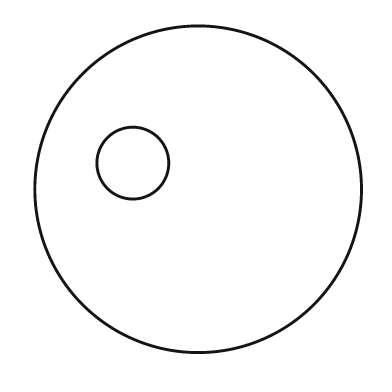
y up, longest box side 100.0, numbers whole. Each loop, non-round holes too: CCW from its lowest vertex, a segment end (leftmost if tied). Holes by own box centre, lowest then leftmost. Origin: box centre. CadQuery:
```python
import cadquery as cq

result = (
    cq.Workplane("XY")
    .moveTo(0.0, 0.0)
    .circle(50.0)
    .moveTo(-20.0, 8.0)
    .circle(11.0)
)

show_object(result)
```